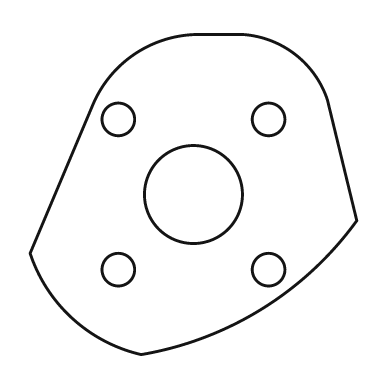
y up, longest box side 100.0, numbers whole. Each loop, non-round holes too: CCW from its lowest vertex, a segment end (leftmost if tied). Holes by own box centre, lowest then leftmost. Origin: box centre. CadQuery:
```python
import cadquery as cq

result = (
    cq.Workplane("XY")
    .moveTo(-16.0, -49.0)
    .threePointArc((21.0, -35.0), (50.0, -8.0))
    .lineTo(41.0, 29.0)
    .threePointArc((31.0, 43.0), (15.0, 49.0))
    .lineTo(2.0, 49.0)
    .threePointArc((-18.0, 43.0), (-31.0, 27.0))
    .lineTo(-50.0, -18.0)
    .threePointArc((-37.0, -38.0), (-16.0, -49.0))
    .close()
    .moveTo(-23.0, -23.0)
    .circle(5.0)
    .moveTo(23.0, -23.0)
    .circle(5.0)
    .moveTo(0.0, 0.0)
    .circle(15.0)
    .moveTo(-23.0, 23.0)
    .circle(5.0)
    .moveTo(23.0, 23.0)
    .circle(5.0)
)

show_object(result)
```